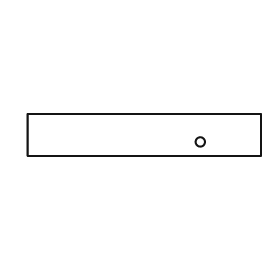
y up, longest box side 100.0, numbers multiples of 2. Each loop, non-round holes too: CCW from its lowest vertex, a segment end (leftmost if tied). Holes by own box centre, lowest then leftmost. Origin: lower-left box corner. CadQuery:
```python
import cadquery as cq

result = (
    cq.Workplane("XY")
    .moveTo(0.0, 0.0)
    .lineTo(100.0, 0.0)
    .lineTo(100.0, 18.0)
    .lineTo(0.0, 18.0)
    .close()
    .moveTo(74.0, 6.0)
    .circle(2.0)
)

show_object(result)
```